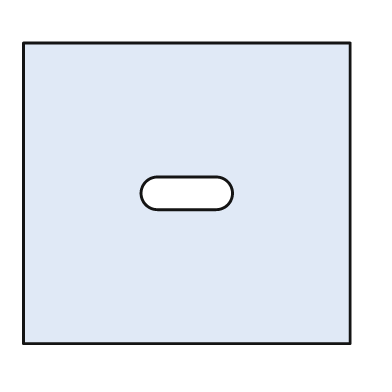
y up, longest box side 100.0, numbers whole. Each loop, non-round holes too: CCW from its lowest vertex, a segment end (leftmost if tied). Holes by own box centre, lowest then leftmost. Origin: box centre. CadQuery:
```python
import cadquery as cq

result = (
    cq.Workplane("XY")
    .moveTo(-50.0, -46.0)
    .lineTo(50.0, -46.0)
    .lineTo(50.0, 46.0)
    .lineTo(-50.0, 46.0)
    .close()
    .moveTo(-9.0, -5.0)
    .lineTo(9.0, -5.0)
    .threePointArc((14.0, 0.0), (9.0, 5.0))
    .lineTo(-9.0, 5.0)
    .threePointArc((-14.0, 0.0), (-9.0, -5.0))
    .close()
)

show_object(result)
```